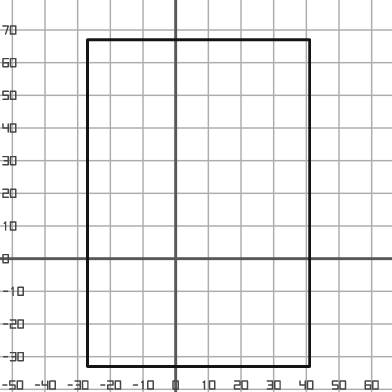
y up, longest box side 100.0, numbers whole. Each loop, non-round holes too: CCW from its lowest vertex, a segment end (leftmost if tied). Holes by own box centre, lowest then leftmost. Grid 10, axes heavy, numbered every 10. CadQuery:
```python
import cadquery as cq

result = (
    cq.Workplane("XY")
    .moveTo(-27.0, -33.0)
    .lineTo(41.0, -33.0)
    .lineTo(41.0, 67.0)
    .lineTo(-27.0, 67.0)
    .close()
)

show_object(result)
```